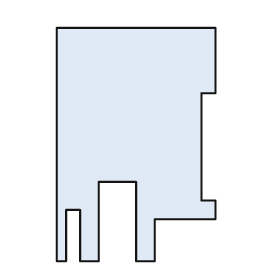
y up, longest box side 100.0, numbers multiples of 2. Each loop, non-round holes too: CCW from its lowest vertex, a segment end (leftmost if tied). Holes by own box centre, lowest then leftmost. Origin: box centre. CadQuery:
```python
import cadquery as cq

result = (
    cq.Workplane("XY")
    .moveTo(-34.0, -50.0)
    .lineTo(-30.0, -50.0)
    .lineTo(-30.0, -28.0)
    .lineTo(-24.0, -28.0)
    .lineTo(-24.0, -50.0)
    .lineTo(-16.0, -50.0)
    .lineTo(-16.0, -16.0)
    .lineTo(0.0, -16.0)
    .lineTo(0.0, -50.0)
    .lineTo(8.0, -50.0)
    .lineTo(8.0, -32.0)
    .lineTo(34.0, -32.0)
    .lineTo(34.0, -24.0)
    .lineTo(28.0, -24.0)
    .lineTo(28.0, 22.0)
    .lineTo(34.0, 22.0)
    .lineTo(34.0, 50.0)
    .lineTo(-34.0, 50.0)
    .close()
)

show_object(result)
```